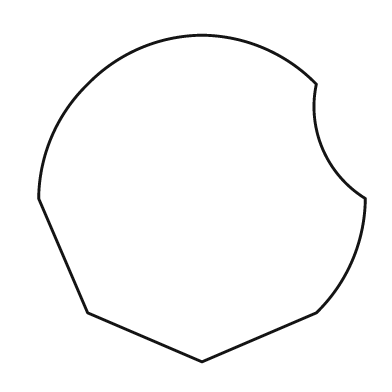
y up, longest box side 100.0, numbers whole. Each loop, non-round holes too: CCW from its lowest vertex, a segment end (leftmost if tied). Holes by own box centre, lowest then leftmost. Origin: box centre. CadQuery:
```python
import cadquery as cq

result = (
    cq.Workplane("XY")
    .moveTo(0.0, -50.0)
    .lineTo(35.0, -35.0)
    .threePointArc((46.0, -19.0), (50.0, 0.0))
    .threePointArc((37.0, 15.0), (35.0, 35.0))
    .threePointArc((19.0, 46.0), (0.0, 50.0))
    .threePointArc((-19.0, 46.0), (-35.0, 35.0))
    .threePointArc((-46.0, 19.0), (-50.0, 0.0))
    .lineTo(-35.0, -35.0)
    .close()
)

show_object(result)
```